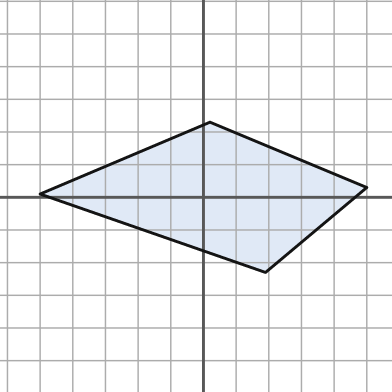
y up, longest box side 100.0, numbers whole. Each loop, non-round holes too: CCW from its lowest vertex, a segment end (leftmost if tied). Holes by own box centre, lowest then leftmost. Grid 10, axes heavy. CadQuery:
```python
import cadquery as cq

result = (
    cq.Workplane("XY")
    .moveTo(19.0, -23.0)
    .lineTo(50.0, 3.0)
    .lineTo(2.0, 23.0)
    .lineTo(-50.0, 1.0)
    .close()
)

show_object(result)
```